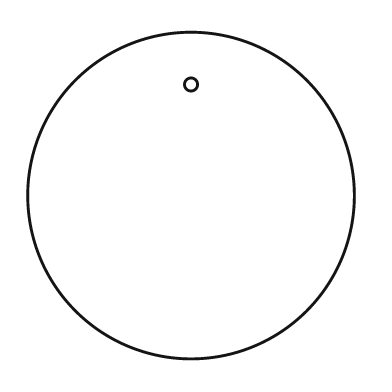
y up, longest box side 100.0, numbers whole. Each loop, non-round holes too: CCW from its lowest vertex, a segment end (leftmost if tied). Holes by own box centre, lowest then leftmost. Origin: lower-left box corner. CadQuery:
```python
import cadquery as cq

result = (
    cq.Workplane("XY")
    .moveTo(50.0, 50.0)
    .circle(50.0)
    .moveTo(50.0, 84.0)
    .circle(2.0)
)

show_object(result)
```